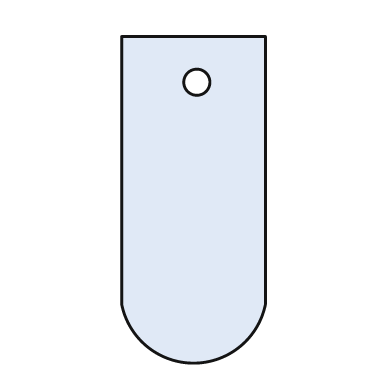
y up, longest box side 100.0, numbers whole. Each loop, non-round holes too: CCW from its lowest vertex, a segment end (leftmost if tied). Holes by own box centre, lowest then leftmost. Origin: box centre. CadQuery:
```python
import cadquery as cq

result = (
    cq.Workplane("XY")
    .moveTo(-22.0, -32.0)
    .threePointArc((0.0, -50.0), (22.0, -32.0))
    .lineTo(22.0, 50.0)
    .lineTo(-22.0, 50.0)
    .close()
    .moveTo(1.0, 36.0)
    .circle(4.0)
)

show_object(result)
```